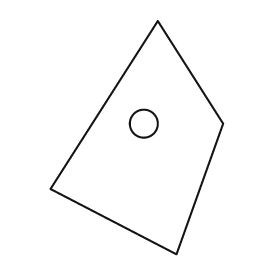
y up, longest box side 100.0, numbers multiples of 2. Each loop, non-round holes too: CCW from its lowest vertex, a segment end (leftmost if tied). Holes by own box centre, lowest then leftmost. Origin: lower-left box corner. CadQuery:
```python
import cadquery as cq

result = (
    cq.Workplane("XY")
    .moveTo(54.0, 0.0)
    .lineTo(74.0, 56.0)
    .lineTo(46.0, 100.0)
    .lineTo(0.0, 28.0)
    .close()
    .moveTo(40.0, 56.0)
    .circle(6.0)
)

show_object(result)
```